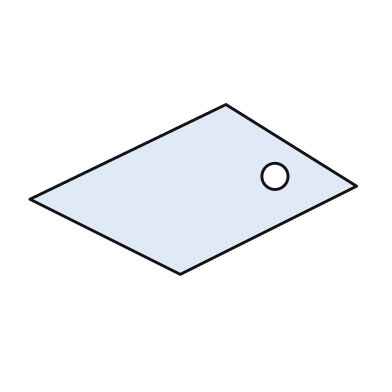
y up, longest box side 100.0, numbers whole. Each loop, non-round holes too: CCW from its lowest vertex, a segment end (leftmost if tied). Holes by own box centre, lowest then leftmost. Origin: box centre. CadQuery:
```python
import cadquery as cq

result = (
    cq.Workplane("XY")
    .moveTo(-4.0, -26.0)
    .lineTo(50.0, 1.0)
    .lineTo(10.0, 26.0)
    .lineTo(-50.0, -3.0)
    .close()
    .moveTo(25.0, 4.0)
    .circle(4.0)
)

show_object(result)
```